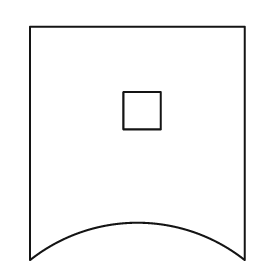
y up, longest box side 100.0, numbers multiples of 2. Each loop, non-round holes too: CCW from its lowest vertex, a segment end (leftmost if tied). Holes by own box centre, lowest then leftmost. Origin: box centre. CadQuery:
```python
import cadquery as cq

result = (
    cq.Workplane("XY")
    .moveTo(-46.0, -50.0)
    .threePointArc((0.0, -34.0), (46.0, -50.0))
    .lineTo(46.0, 50.0)
    .lineTo(-46.0, 50.0)
    .close()
    .moveTo(-6.0, 6.0)
    .lineTo(10.0, 6.0)
    .lineTo(10.0, 22.0)
    .lineTo(-6.0, 22.0)
    .close()
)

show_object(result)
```